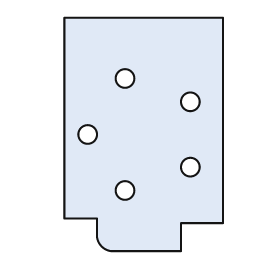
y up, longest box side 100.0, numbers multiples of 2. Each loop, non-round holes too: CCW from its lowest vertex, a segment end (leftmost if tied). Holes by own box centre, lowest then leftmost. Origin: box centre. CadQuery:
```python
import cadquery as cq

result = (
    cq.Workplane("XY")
    .moveTo(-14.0, -50.0)
    .lineTo(16.0, -50.0)
    .lineTo(16.0, -38.0)
    .lineTo(34.0, -38.0)
    .lineTo(34.0, 50.0)
    .lineTo(-34.0, 50.0)
    .lineTo(-34.0, -36.0)
    .lineTo(-20.0, -36.0)
    .lineTo(-20.0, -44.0)
    .threePointArc((-18.0, -48.0), (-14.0, -50.0))
    .close()
    .moveTo(-8.0, -24.0)
    .circle(4.0)
    .moveTo(20.0, -14.0)
    .circle(4.0)
    .moveTo(-24.0, 0.0)
    .circle(4.0)
    .moveTo(20.0, 14.0)
    .circle(4.0)
    .moveTo(-8.0, 24.0)
    .circle(4.0)
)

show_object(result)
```